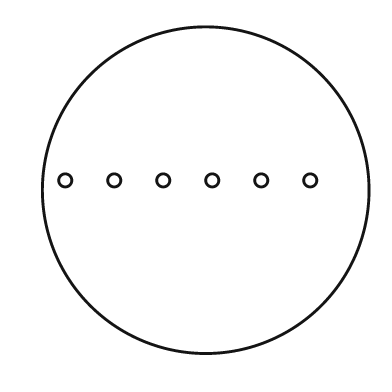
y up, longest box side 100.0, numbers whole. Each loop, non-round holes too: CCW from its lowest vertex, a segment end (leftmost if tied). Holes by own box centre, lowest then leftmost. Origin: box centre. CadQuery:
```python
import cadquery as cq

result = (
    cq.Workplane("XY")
    .moveTo(0.0, 0.0)
    .circle(50.0)
    .moveTo(-43.0, 3.0)
    .circle(2.0)
    .moveTo(-28.0, 3.0)
    .circle(2.0)
    .moveTo(-13.0, 3.0)
    .circle(2.0)
    .moveTo(2.0, 3.0)
    .circle(2.0)
    .moveTo(17.0, 3.0)
    .circle(2.0)
    .moveTo(32.0, 3.0)
    .circle(2.0)
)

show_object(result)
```